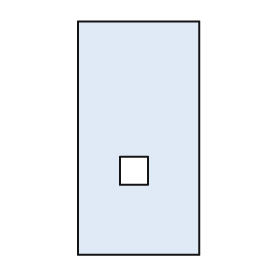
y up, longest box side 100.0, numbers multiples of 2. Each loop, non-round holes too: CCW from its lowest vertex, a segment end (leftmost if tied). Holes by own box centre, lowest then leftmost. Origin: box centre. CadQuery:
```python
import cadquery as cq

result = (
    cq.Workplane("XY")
    .moveTo(-26.0, -50.0)
    .lineTo(26.0, -50.0)
    .lineTo(26.0, 50.0)
    .lineTo(-26.0, 50.0)
    .close()
    .moveTo(-8.0, -20.0)
    .lineTo(4.0, -20.0)
    .lineTo(4.0, -8.0)
    .lineTo(-8.0, -8.0)
    .close()
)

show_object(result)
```